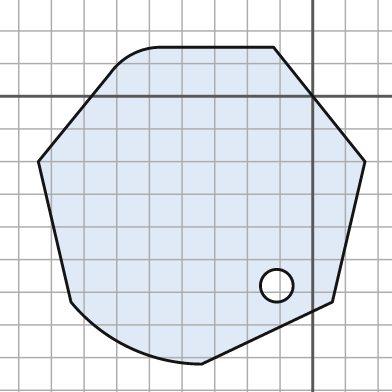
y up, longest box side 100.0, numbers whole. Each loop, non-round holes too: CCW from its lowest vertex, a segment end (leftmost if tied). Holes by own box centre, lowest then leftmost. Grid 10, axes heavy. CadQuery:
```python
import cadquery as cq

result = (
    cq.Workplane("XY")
    .moveTo(-34.0, -82.0)
    .lineTo(6.0, -63.0)
    .lineTo(16.0, -20.0)
    .lineTo(-12.0, 15.0)
    .lineTo(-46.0, 15.0)
    .threePointArc((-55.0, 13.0), (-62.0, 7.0))
    .lineTo(-84.0, -20.0)
    .lineTo(-74.0, -63.0)
    .threePointArc((-56.0, -77.0), (-34.0, -82.0))
    .close()
    .moveTo(-11.0, -58.0)
    .circle(5.0)
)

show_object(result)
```